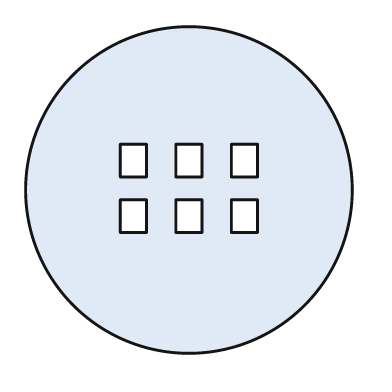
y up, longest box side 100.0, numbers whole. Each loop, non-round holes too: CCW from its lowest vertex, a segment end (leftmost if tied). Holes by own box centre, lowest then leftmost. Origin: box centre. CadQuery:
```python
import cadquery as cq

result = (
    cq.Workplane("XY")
    .moveTo(0.0, 0.0)
    .circle(50.0)
    .moveTo(-21.0, -13.0)
    .lineTo(-13.0, -13.0)
    .lineTo(-13.0, -3.0)
    .lineTo(-21.0, -3.0)
    .close()
    .moveTo(-4.0, -13.0)
    .lineTo(4.0, -13.0)
    .lineTo(4.0, -3.0)
    .lineTo(-4.0, -3.0)
    .close()
    .moveTo(13.0, -13.0)
    .lineTo(21.0, -13.0)
    .lineTo(21.0, -3.0)
    .lineTo(13.0, -3.0)
    .close()
    .moveTo(-21.0, 4.0)
    .lineTo(-13.0, 4.0)
    .lineTo(-13.0, 14.0)
    .lineTo(-21.0, 14.0)
    .close()
    .moveTo(-4.0, 4.0)
    .lineTo(4.0, 4.0)
    .lineTo(4.0, 14.0)
    .lineTo(-4.0, 14.0)
    .close()
    .moveTo(13.0, 4.0)
    .lineTo(21.0, 4.0)
    .lineTo(21.0, 14.0)
    .lineTo(13.0, 14.0)
    .close()
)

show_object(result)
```